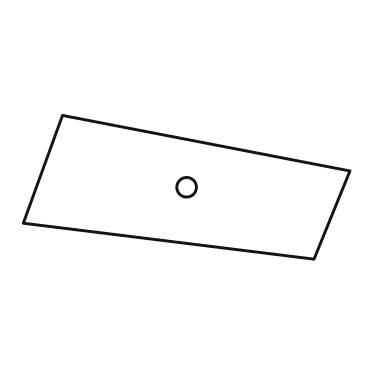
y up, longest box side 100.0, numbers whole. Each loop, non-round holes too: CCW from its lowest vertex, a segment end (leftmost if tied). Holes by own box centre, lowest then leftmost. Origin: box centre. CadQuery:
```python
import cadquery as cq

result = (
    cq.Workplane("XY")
    .moveTo(39.0, -22.0)
    .lineTo(50.0, 5.0)
    .lineTo(-38.0, 22.0)
    .lineTo(-50.0, -11.0)
    .close()
    .moveTo(0.0, 0.0)
    .circle(3.0)
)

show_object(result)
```